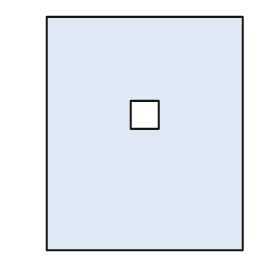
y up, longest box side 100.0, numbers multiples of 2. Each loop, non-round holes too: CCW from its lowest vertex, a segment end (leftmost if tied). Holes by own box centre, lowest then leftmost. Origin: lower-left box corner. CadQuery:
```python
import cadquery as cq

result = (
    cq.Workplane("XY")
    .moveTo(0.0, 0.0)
    .lineTo(84.0, 0.0)
    .lineTo(84.0, 100.0)
    .lineTo(0.0, 100.0)
    .close()
    .moveTo(36.0, 52.0)
    .lineTo(48.0, 52.0)
    .lineTo(48.0, 64.0)
    .lineTo(36.0, 64.0)
    .close()
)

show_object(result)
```